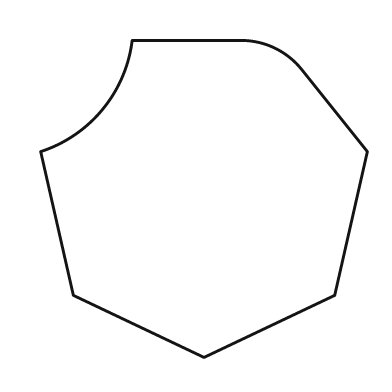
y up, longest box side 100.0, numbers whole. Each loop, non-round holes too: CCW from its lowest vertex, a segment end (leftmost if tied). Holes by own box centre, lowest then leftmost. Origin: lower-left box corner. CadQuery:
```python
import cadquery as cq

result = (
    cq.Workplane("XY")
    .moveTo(50.0, 0.0)
    .lineTo(90.0, 19.0)
    .lineTo(100.0, 63.0)
    .lineTo(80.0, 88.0)
    .threePointArc((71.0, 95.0), (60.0, 97.0))
    .lineTo(28.0, 97.0)
    .threePointArc((19.0, 76.0), (0.0, 63.0))
    .lineTo(10.0, 19.0)
    .close()
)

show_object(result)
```